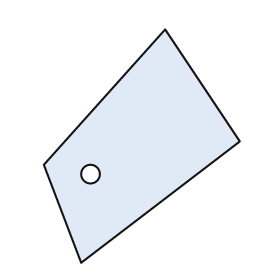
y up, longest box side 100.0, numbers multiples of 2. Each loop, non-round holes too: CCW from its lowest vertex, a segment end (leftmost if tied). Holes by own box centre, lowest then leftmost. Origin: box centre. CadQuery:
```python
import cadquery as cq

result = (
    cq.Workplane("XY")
    .moveTo(-26.0, -50.0)
    .lineTo(42.0, 2.0)
    .lineTo(10.0, 50.0)
    .lineTo(-42.0, -8.0)
    .close()
    .moveTo(-22.0, -12.0)
    .circle(4.0)
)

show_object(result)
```